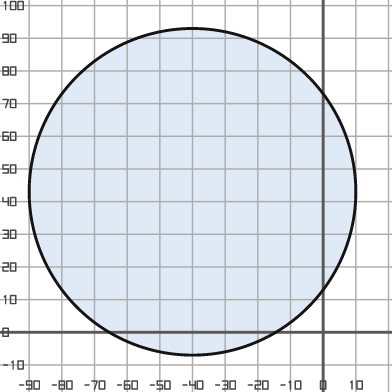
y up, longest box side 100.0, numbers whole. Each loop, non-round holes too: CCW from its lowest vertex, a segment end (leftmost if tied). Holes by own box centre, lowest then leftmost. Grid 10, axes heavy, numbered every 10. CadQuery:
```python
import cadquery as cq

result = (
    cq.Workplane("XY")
    .moveTo(-40.0, 43.0)
    .circle(50.0)
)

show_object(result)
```